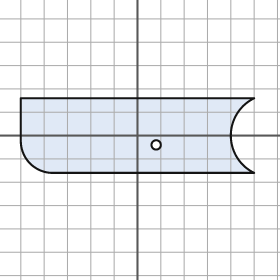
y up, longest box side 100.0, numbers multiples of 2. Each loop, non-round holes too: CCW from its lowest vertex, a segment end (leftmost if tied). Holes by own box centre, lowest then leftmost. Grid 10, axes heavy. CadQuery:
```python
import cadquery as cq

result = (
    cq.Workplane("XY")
    .moveTo(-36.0, -16.0)
    .lineTo(50.0, -16.0)
    .threePointArc((40.0, 0.0), (50.0, 16.0))
    .lineTo(-50.0, 16.0)
    .lineTo(-50.0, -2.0)
    .threePointArc((-46.0, -12.0), (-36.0, -16.0))
    .close()
    .moveTo(8.0, -4.0)
    .circle(2.0)
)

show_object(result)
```